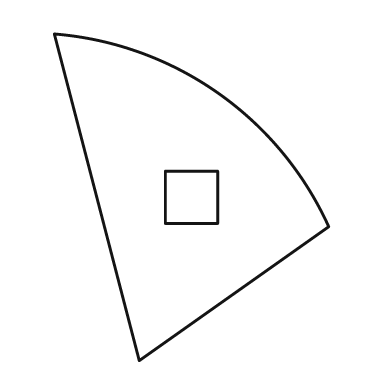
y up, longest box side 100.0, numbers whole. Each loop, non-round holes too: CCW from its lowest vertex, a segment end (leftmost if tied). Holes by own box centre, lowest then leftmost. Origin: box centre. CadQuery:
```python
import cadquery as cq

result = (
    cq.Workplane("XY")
    .moveTo(-16.0, -50.0)
    .lineTo(42.0, -9.0)
    .threePointArc((8.0, 32.0), (-42.0, 50.0))
    .close()
    .moveTo(-8.0, -8.0)
    .lineTo(8.0, -8.0)
    .lineTo(8.0, 8.0)
    .lineTo(-8.0, 8.0)
    .close()
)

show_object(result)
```